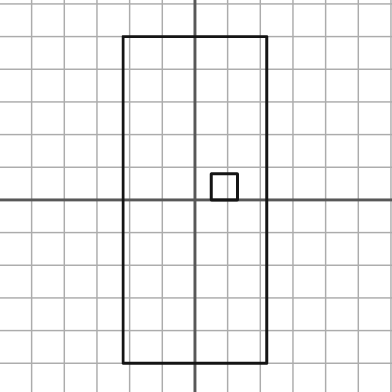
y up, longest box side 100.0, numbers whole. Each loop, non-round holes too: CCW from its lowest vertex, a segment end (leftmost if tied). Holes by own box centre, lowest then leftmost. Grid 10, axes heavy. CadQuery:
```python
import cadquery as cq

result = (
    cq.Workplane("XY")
    .moveTo(-22.0, -50.0)
    .lineTo(22.0, -50.0)
    .lineTo(22.0, 50.0)
    .lineTo(-22.0, 50.0)
    .close()
    .moveTo(5.0, 0.0)
    .lineTo(13.0, 0.0)
    .lineTo(13.0, 8.0)
    .lineTo(5.0, 8.0)
    .close()
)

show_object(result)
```